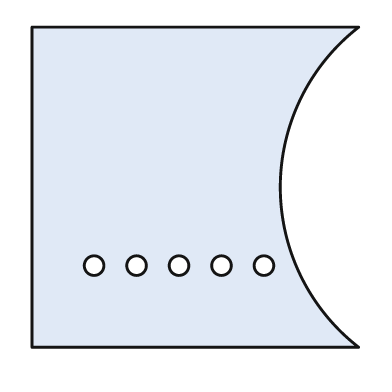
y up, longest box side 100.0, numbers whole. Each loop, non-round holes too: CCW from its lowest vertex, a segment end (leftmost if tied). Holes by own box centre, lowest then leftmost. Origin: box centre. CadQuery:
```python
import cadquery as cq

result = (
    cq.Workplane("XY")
    .moveTo(-50.0, -49.0)
    .lineTo(50.0, -49.0)
    .threePointArc((26.0, 0.0), (50.0, 49.0))
    .lineTo(-50.0, 49.0)
    .close()
    .moveTo(-31.0, -24.0)
    .circle(3.0)
    .moveTo(-18.0, -24.0)
    .circle(3.0)
    .moveTo(-5.0, -24.0)
    .circle(3.0)
    .moveTo(8.0, -24.0)
    .circle(3.0)
    .moveTo(21.0, -24.0)
    .circle(3.0)
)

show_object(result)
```